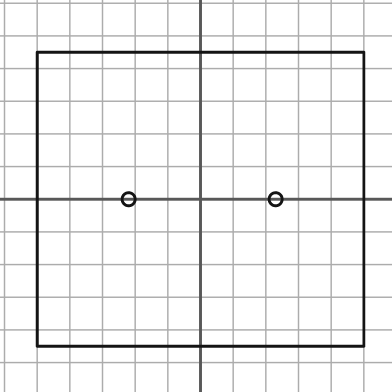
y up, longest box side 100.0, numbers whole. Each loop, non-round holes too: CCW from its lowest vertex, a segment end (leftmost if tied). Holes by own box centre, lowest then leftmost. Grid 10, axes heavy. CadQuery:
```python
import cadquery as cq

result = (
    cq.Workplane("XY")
    .moveTo(-50.0, -45.0)
    .lineTo(50.0, -45.0)
    .lineTo(50.0, 45.0)
    .lineTo(-50.0, 45.0)
    .close()
    .moveTo(-22.0, 0.0)
    .circle(2.0)
    .moveTo(23.0, 0.0)
    .circle(2.0)
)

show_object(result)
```